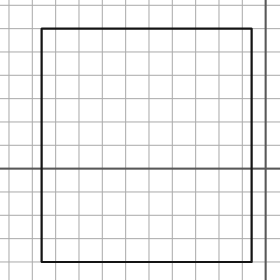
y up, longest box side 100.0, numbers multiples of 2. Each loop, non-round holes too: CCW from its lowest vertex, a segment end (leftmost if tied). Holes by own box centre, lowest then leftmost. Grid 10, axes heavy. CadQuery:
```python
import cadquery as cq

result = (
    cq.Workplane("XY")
    .moveTo(-96.0, -40.0)
    .lineTo(-6.0, -40.0)
    .lineTo(-6.0, 60.0)
    .lineTo(-96.0, 60.0)
    .close()
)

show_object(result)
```